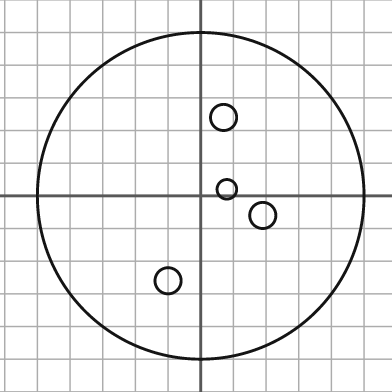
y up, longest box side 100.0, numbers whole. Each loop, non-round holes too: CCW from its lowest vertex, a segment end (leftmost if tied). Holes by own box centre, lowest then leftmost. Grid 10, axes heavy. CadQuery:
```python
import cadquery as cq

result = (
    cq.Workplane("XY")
    .moveTo(0.0, 0.0)
    .circle(50.0)
    .moveTo(-10.0, -26.0)
    .circle(4.0)
    .moveTo(19.0, -6.0)
    .circle(4.0)
    .moveTo(8.0, 2.0)
    .circle(3.0)
    .moveTo(7.0, 24.0)
    .circle(4.0)
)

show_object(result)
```